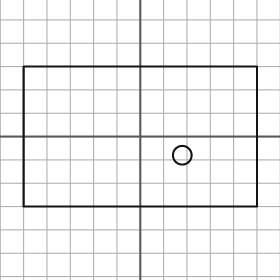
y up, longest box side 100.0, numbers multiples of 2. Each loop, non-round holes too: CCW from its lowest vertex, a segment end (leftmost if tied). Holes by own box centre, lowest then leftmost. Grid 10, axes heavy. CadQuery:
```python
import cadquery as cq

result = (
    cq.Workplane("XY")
    .moveTo(-50.0, -30.0)
    .lineTo(50.0, -30.0)
    .lineTo(50.0, 30.0)
    .lineTo(-50.0, 30.0)
    .close()
    .moveTo(18.0, -8.0)
    .circle(4.0)
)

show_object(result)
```